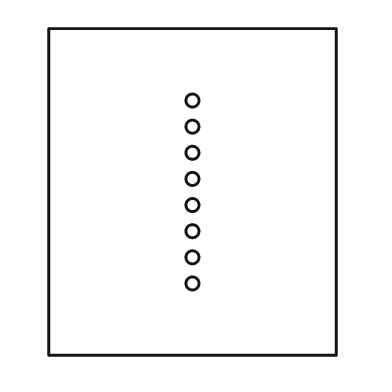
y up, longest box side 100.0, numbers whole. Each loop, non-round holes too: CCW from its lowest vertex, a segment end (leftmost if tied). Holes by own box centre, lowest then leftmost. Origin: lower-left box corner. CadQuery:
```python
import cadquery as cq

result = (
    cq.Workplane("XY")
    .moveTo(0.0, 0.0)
    .lineTo(88.0, 0.0)
    .lineTo(88.0, 100.0)
    .lineTo(0.0, 100.0)
    .close()
    .moveTo(44.0, 22.0)
    .circle(2.0)
    .moveTo(44.0, 30.0)
    .circle(2.0)
    .moveTo(44.0, 38.0)
    .circle(2.0)
    .moveTo(44.0, 46.0)
    .circle(2.0)
    .moveTo(44.0, 54.0)
    .circle(2.0)
    .moveTo(44.0, 62.0)
    .circle(2.0)
    .moveTo(44.0, 70.0)
    .circle(2.0)
    .moveTo(44.0, 78.0)
    .circle(2.0)
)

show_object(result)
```